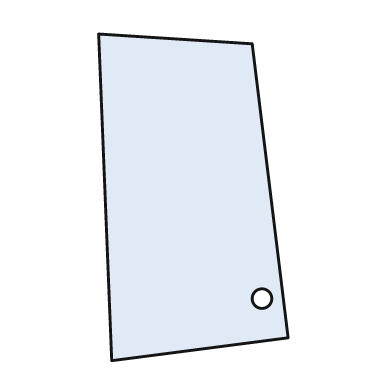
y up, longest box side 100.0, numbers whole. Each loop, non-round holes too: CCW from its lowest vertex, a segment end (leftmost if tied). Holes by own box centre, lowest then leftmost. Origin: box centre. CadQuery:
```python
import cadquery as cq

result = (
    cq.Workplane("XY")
    .moveTo(-25.0, -50.0)
    .lineTo(29.0, -43.0)
    .lineTo(18.0, 47.0)
    .lineTo(-29.0, 50.0)
    .close()
    .moveTo(21.0, -31.0)
    .circle(3.0)
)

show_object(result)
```